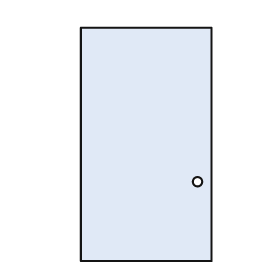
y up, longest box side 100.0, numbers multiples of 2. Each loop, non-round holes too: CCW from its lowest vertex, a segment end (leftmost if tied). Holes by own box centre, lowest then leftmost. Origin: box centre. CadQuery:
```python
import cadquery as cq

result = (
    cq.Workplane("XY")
    .moveTo(-28.0, -50.0)
    .lineTo(28.0, -50.0)
    .lineTo(28.0, 50.0)
    .lineTo(-28.0, 50.0)
    .close()
    .moveTo(22.0, -16.0)
    .circle(2.0)
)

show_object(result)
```